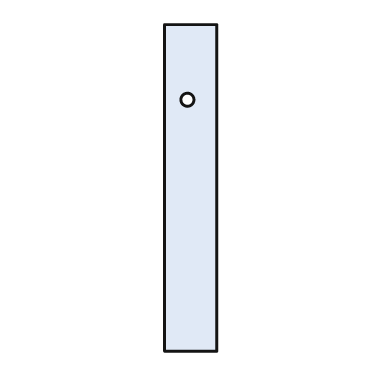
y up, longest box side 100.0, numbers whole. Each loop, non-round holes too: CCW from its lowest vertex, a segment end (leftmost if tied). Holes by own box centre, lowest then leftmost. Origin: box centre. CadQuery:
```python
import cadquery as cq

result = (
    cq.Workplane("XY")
    .moveTo(-8.0, -50.0)
    .lineTo(8.0, -50.0)
    .lineTo(8.0, 50.0)
    .lineTo(-8.0, 50.0)
    .close()
    .moveTo(-1.0, 27.0)
    .circle(2.0)
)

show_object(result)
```